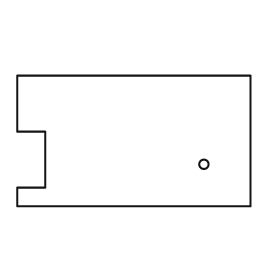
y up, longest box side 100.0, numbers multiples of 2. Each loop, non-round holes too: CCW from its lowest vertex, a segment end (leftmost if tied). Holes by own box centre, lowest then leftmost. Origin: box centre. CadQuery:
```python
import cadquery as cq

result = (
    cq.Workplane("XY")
    .moveTo(-50.0, -28.0)
    .lineTo(50.0, -28.0)
    .lineTo(50.0, 28.0)
    .lineTo(-50.0, 28.0)
    .lineTo(-50.0, 4.0)
    .lineTo(-38.0, 4.0)
    .lineTo(-38.0, -20.0)
    .lineTo(-50.0, -20.0)
    .close()
    .moveTo(30.0, -10.0)
    .circle(2.0)
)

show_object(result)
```